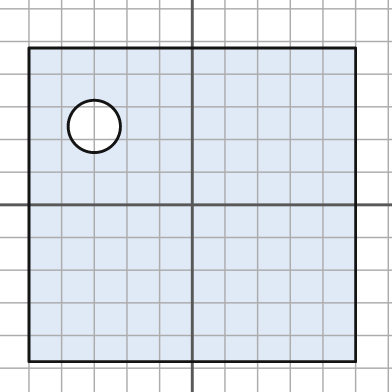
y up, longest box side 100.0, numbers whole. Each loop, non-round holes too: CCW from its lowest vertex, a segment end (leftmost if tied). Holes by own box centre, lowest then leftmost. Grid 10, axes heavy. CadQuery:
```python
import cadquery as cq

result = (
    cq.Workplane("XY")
    .moveTo(-50.0, -48.0)
    .lineTo(50.0, -48.0)
    .lineTo(50.0, 48.0)
    .lineTo(-50.0, 48.0)
    .close()
    .moveTo(-30.0, 24.0)
    .circle(8.0)
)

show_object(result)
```